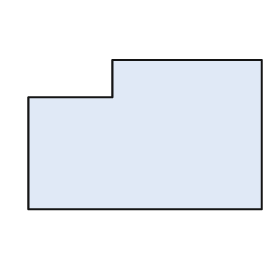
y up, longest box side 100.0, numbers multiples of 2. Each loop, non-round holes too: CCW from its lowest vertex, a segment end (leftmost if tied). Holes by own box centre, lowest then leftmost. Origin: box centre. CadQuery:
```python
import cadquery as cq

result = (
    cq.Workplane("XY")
    .moveTo(-50.0, -32.0)
    .lineTo(50.0, -32.0)
    .lineTo(50.0, 32.0)
    .lineTo(-14.0, 32.0)
    .lineTo(-14.0, 16.0)
    .lineTo(-50.0, 16.0)
    .close()
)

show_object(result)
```